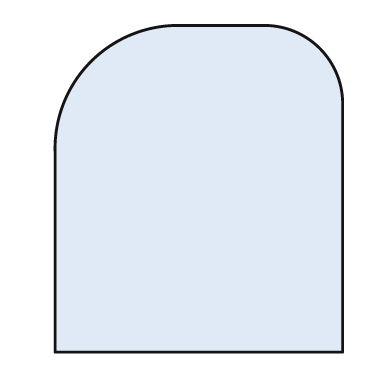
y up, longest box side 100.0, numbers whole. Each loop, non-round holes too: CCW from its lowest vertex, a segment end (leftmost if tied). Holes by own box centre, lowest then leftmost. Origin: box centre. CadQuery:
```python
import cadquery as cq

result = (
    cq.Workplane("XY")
    .moveTo(-44.0, -50.0)
    .lineTo(44.0, -50.0)
    .lineTo(44.0, 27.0)
    .threePointArc((37.0, 43.0), (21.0, 50.0))
    .lineTo(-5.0, 50.0)
    .threePointArc((-33.0, 39.0), (-44.0, 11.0))
    .close()
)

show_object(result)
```